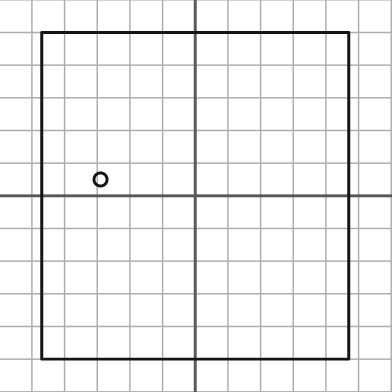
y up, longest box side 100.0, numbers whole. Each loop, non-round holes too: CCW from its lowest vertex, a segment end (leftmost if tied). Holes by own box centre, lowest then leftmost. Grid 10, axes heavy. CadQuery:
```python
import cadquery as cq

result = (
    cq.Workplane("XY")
    .moveTo(-47.0, -50.0)
    .lineTo(47.0, -50.0)
    .lineTo(47.0, 50.0)
    .lineTo(-47.0, 50.0)
    .close()
    .moveTo(-29.0, 5.0)
    .circle(2.0)
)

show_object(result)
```